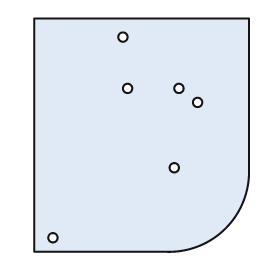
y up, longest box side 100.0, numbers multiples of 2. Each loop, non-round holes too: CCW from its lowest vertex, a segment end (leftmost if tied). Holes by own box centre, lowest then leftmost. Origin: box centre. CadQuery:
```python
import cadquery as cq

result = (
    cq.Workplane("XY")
    .moveTo(-46.0, -50.0)
    .lineTo(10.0, -50.0)
    .threePointArc((36.0, -40.0), (46.0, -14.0))
    .lineTo(46.0, 50.0)
    .lineTo(-46.0, 50.0)
    .close()
    .moveTo(-38.0, -44.0)
    .circle(2.0)
    .moveTo(14.0, -14.0)
    .circle(2.0)
    .moveTo(24.0, 14.0)
    .circle(2.0)
    .moveTo(-6.0, 20.0)
    .circle(2.0)
    .moveTo(16.0, 20.0)
    .circle(2.0)
    .moveTo(-8.0, 42.0)
    .circle(2.0)
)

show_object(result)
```